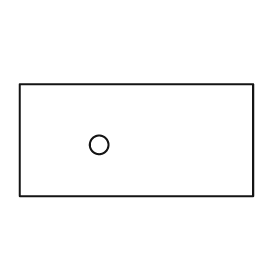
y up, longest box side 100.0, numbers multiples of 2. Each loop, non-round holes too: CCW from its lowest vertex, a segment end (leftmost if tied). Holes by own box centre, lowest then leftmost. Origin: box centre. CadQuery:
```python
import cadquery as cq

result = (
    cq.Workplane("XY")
    .moveTo(-50.0, -24.0)
    .lineTo(50.0, -24.0)
    .lineTo(50.0, 24.0)
    .lineTo(-50.0, 24.0)
    .close()
    .moveTo(-16.0, -2.0)
    .circle(4.0)
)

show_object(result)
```